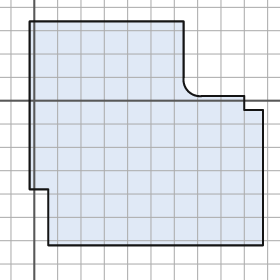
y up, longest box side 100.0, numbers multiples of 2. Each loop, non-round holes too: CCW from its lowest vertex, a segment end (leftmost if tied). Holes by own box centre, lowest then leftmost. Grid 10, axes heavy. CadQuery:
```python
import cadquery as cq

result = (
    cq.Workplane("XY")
    .moveTo(6.0, -62.0)
    .lineTo(98.0, -62.0)
    .lineTo(98.0, -4.0)
    .lineTo(90.0, -4.0)
    .lineTo(90.0, 2.0)
    .lineTo(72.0, 2.0)
    .threePointArc((66.0, 4.0), (64.0, 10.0))
    .lineTo(64.0, 34.0)
    .lineTo(-2.0, 34.0)
    .lineTo(-2.0, -38.0)
    .lineTo(6.0, -38.0)
    .close()
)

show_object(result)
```